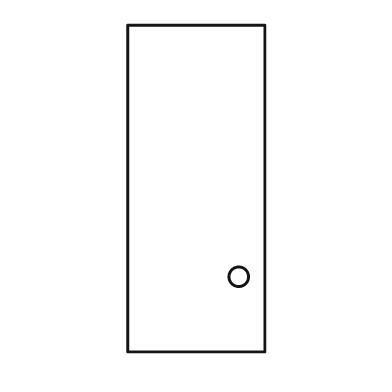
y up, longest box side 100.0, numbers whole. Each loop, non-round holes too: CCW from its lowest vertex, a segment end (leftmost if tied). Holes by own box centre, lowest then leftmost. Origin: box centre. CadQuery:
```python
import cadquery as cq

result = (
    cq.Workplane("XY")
    .moveTo(-21.0, -50.0)
    .lineTo(21.0, -50.0)
    .lineTo(21.0, 50.0)
    .lineTo(-21.0, 50.0)
    .close()
    .moveTo(13.0, -27.0)
    .circle(3.0)
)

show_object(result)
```